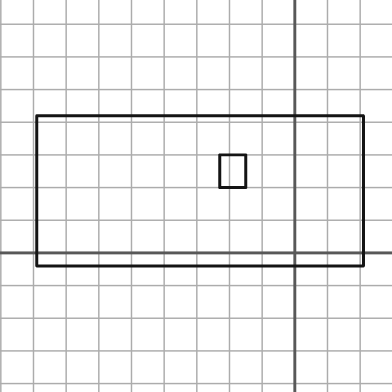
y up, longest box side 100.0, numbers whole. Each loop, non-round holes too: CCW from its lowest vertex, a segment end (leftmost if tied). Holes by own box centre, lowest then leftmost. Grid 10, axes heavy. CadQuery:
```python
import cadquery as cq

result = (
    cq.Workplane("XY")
    .moveTo(-79.0, -4.0)
    .lineTo(21.0, -4.0)
    .lineTo(21.0, 42.0)
    .lineTo(-79.0, 42.0)
    .close()
    .moveTo(-23.0, 20.0)
    .lineTo(-15.0, 20.0)
    .lineTo(-15.0, 30.0)
    .lineTo(-23.0, 30.0)
    .close()
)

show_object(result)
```